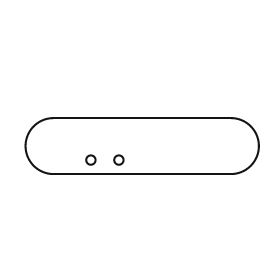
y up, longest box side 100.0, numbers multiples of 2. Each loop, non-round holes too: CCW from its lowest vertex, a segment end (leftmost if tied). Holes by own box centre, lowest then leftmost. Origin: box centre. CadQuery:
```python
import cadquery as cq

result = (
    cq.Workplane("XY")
    .moveTo(-38.0, -12.0)
    .lineTo(38.0, -12.0)
    .threePointArc((50.0, 0.0), (38.0, 12.0))
    .lineTo(-38.0, 12.0)
    .threePointArc((-50.0, 0.0), (-38.0, -12.0))
    .close()
    .moveTo(-22.0, -6.0)
    .circle(2.0)
    .moveTo(-10.0, -6.0)
    .circle(2.0)
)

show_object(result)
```